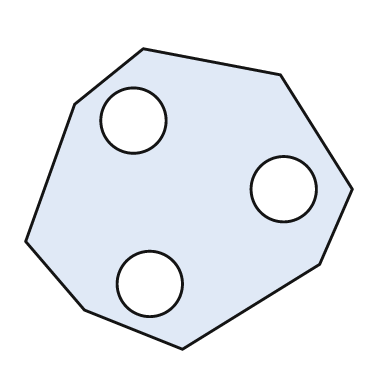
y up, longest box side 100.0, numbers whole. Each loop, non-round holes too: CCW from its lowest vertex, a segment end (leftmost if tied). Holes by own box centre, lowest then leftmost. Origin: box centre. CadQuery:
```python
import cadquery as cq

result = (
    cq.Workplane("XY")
    .moveTo(-2.0, -46.0)
    .lineTo(40.0, -20.0)
    .lineTo(50.0, 3.0)
    .lineTo(28.0, 38.0)
    .lineTo(-14.0, 46.0)
    .lineTo(-35.0, 29.0)
    .lineTo(-50.0, -13.0)
    .lineTo(-32.0, -34.0)
    .close()
    .moveTo(-12.0, -26.0)
    .circle(10.0)
    .moveTo(29.0, 3.0)
    .circle(10.0)
    .moveTo(-17.0, 24.0)
    .circle(10.0)
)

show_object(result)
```